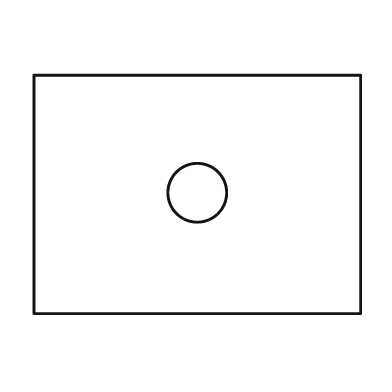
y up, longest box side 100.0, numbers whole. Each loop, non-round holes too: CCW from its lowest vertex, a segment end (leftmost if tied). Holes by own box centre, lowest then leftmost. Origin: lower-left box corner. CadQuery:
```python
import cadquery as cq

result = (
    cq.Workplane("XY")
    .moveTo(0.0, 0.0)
    .lineTo(100.0, 0.0)
    .lineTo(100.0, 73.0)
    .lineTo(0.0, 73.0)
    .close()
    .moveTo(50.0, 37.0)
    .circle(9.0)
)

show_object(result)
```